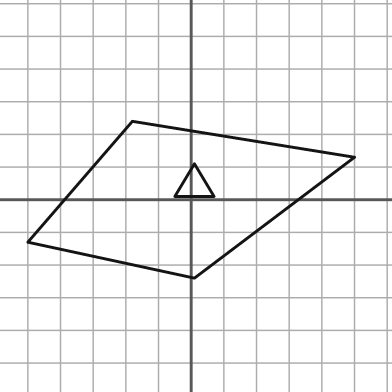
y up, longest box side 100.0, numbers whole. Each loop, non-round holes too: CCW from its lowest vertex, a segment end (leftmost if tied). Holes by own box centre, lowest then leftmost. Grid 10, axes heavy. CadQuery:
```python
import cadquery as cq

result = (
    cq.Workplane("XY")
    .moveTo(1.0, -24.0)
    .lineTo(50.0, 13.0)
    .lineTo(-18.0, 24.0)
    .lineTo(-50.0, -13.0)
    .close()
    .moveTo(-5.0, 1.0)
    .lineTo(7.0, 1.0)
    .lineTo(1.0, 11.0)
    .close()
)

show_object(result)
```